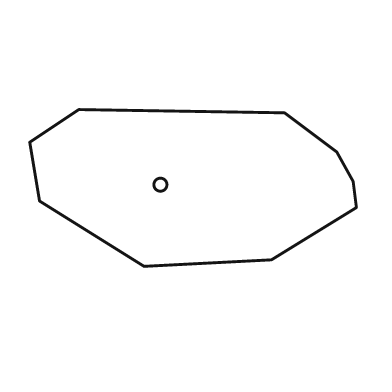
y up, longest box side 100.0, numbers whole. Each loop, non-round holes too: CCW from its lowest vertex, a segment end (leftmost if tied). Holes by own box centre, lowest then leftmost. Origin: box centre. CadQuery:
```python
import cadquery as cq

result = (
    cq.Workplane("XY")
    .moveTo(-15.0, -24.0)
    .lineTo(24.0, -22.0)
    .lineTo(50.0, -6.0)
    .lineTo(49.0, 2.0)
    .lineTo(44.0, 11.0)
    .lineTo(28.0, 23.0)
    .lineTo(-35.0, 24.0)
    .lineTo(-50.0, 14.0)
    .lineTo(-47.0, -4.0)
    .close()
    .moveTo(-10.0, 1.0)
    .circle(2.0)
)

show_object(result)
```